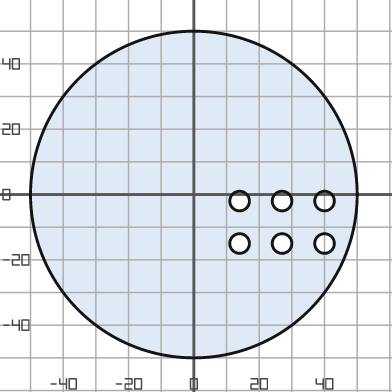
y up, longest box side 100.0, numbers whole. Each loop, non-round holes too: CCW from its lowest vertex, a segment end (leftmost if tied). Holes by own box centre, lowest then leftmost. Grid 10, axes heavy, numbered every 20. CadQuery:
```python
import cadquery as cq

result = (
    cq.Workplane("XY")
    .moveTo(0.0, 0.0)
    .circle(50.0)
    .moveTo(14.0, -15.0)
    .circle(3.0)
    .moveTo(27.0, -15.0)
    .circle(3.0)
    .moveTo(40.0, -15.0)
    .circle(3.0)
    .moveTo(14.0, -2.0)
    .circle(3.0)
    .moveTo(27.0, -2.0)
    .circle(3.0)
    .moveTo(40.0, -2.0)
    .circle(3.0)
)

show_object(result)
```